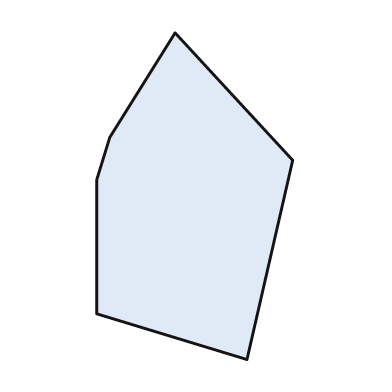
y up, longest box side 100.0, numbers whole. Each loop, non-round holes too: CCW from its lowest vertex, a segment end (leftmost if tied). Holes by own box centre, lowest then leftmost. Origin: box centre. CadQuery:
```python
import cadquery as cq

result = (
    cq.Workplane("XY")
    .moveTo(16.0, -50.0)
    .lineTo(30.0, 11.0)
    .lineTo(-6.0, 50.0)
    .lineTo(-26.0, 18.0)
    .lineTo(-30.0, 5.0)
    .lineTo(-30.0, -36.0)
    .close()
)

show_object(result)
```